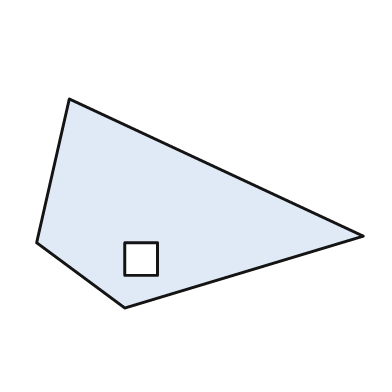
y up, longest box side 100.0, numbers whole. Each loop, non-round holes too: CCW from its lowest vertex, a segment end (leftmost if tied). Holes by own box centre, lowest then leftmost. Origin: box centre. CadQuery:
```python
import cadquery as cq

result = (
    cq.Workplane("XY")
    .moveTo(-23.0, -32.0)
    .lineTo(50.0, -10.0)
    .lineTo(-40.0, 32.0)
    .lineTo(-50.0, -12.0)
    .close()
    .moveTo(-23.0, -22.0)
    .lineTo(-13.0, -22.0)
    .lineTo(-13.0, -12.0)
    .lineTo(-23.0, -12.0)
    .close()
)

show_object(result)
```